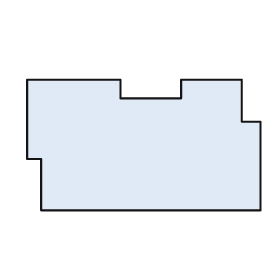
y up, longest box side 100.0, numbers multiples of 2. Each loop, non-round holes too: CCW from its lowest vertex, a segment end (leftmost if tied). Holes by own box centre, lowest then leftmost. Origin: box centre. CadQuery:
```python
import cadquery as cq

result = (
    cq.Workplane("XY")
    .moveTo(-44.0, -28.0)
    .lineTo(50.0, -28.0)
    .lineTo(50.0, 10.0)
    .lineTo(42.0, 10.0)
    .lineTo(42.0, 28.0)
    .lineTo(16.0, 28.0)
    .lineTo(16.0, 20.0)
    .lineTo(-10.0, 20.0)
    .lineTo(-10.0, 28.0)
    .lineTo(-50.0, 28.0)
    .lineTo(-50.0, -6.0)
    .lineTo(-44.0, -6.0)
    .close()
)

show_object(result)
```